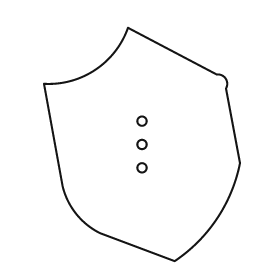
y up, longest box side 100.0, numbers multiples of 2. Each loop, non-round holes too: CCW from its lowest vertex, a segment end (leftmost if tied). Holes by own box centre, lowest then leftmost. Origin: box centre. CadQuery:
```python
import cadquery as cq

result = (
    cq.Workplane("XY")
    .moveTo(14.0, -50.0)
    .threePointArc((32.0, -32.0), (42.0, -8.0))
    .lineTo(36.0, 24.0)
    .threePointArc((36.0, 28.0), (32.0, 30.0))
    .lineTo(-6.0, 50.0)
    .threePointArc((-20.0, 32.0), (-42.0, 26.0))
    .lineTo(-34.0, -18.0)
    .threePointArc((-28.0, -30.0), (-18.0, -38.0))
    .close()
    .moveTo(0.0, -10.0)
    .circle(2.0)
    .moveTo(0.0, 0.0)
    .circle(2.0)
    .moveTo(0.0, 10.0)
    .circle(2.0)
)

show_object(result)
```